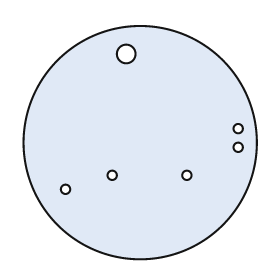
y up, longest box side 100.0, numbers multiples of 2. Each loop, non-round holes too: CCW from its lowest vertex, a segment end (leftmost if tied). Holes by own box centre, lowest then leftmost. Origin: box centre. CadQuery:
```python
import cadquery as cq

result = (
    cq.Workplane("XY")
    .moveTo(0.0, 0.0)
    .circle(50.0)
    .moveTo(-32.0, -20.0)
    .circle(2.0)
    .moveTo(-12.0, -14.0)
    .circle(2.0)
    .moveTo(20.0, -14.0)
    .circle(2.0)
    .moveTo(42.0, -2.0)
    .circle(2.0)
    .moveTo(42.0, 6.0)
    .circle(2.0)
    .moveTo(-6.0, 38.0)
    .circle(4.0)
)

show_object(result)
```